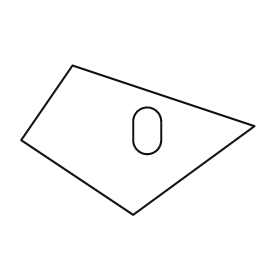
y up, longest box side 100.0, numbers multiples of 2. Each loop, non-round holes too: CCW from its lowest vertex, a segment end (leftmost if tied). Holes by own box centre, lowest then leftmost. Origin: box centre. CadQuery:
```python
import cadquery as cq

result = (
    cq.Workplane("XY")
    .moveTo(-2.0, -32.0)
    .lineTo(50.0, 6.0)
    .lineTo(-28.0, 32.0)
    .lineTo(-50.0, 0.0)
    .close()
    .moveTo(-2.0, 0.0)
    .threePointArc((4.0, -6.0), (10.0, 0.0))
    .lineTo(10.0, 8.0)
    .threePointArc((4.0, 14.0), (-2.0, 8.0))
    .close()
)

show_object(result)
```